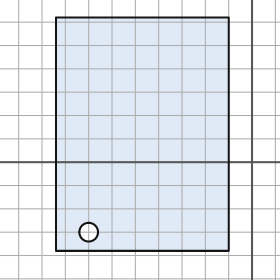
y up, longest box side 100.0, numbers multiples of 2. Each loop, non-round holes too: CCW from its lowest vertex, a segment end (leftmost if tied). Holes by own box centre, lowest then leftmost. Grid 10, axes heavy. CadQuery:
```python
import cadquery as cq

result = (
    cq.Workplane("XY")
    .moveTo(-84.0, -38.0)
    .lineTo(-10.0, -38.0)
    .lineTo(-10.0, 62.0)
    .lineTo(-84.0, 62.0)
    .close()
    .moveTo(-70.0, -30.0)
    .circle(4.0)
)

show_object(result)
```